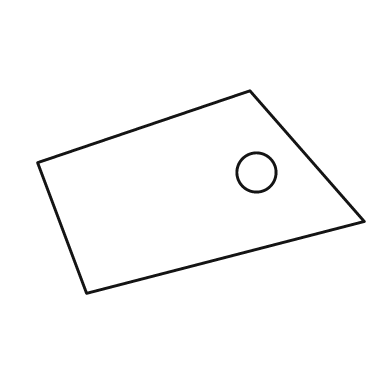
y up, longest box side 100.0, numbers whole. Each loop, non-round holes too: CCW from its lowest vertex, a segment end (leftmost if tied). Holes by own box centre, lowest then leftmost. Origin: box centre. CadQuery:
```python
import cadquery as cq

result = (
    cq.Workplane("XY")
    .moveTo(-35.0, -31.0)
    .lineTo(50.0, -9.0)
    .lineTo(15.0, 31.0)
    .lineTo(-50.0, 9.0)
    .close()
    .moveTo(17.0, 6.0)
    .circle(6.0)
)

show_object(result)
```